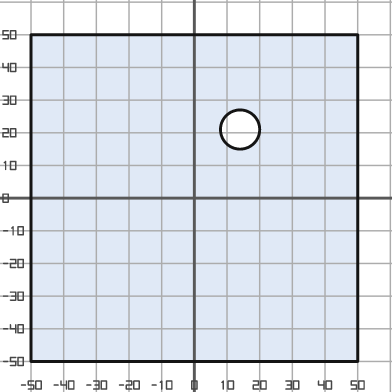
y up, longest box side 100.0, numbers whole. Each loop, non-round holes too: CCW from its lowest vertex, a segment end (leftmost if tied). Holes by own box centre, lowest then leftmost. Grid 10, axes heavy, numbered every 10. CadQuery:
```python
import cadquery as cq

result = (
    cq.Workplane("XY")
    .moveTo(-50.0, -50.0)
    .lineTo(50.0, -50.0)
    .lineTo(50.0, 50.0)
    .lineTo(-50.0, 50.0)
    .close()
    .moveTo(14.0, 21.0)
    .circle(6.0)
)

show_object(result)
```